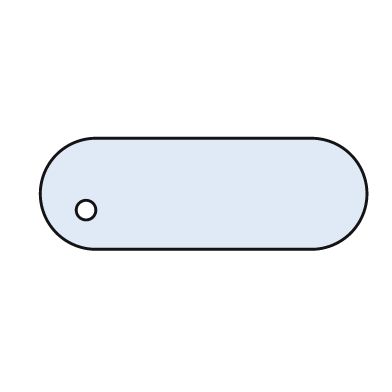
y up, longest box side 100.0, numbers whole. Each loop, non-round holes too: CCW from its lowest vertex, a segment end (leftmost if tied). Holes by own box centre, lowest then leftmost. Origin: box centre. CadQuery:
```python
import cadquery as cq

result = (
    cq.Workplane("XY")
    .moveTo(-33.0, -17.0)
    .lineTo(33.0, -17.0)
    .threePointArc((50.0, 0.0), (33.0, 17.0))
    .lineTo(-33.0, 17.0)
    .threePointArc((-50.0, 0.0), (-33.0, -17.0))
    .close()
    .moveTo(-36.0, -5.0)
    .circle(3.0)
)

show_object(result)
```